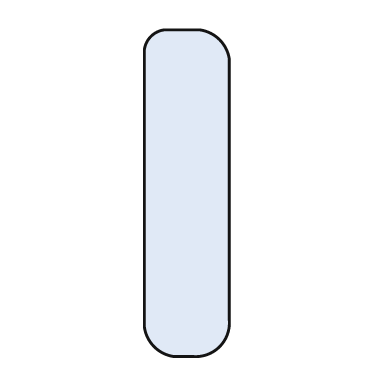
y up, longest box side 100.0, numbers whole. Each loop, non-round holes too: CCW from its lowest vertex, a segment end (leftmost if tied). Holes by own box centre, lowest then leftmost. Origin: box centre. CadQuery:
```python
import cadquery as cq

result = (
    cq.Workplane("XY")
    .moveTo(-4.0, -50.0)
    .lineTo(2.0, -50.0)
    .threePointArc((10.0, -47.0), (13.0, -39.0))
    .lineTo(13.0, 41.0)
    .threePointArc((10.0, 47.0), (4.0, 50.0))
    .lineTo(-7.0, 50.0)
    .threePointArc((-11.0, 48.0), (-13.0, 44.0))
    .lineTo(-13.0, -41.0)
    .threePointArc((-10.0, -47.0), (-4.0, -50.0))
    .close()
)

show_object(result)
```